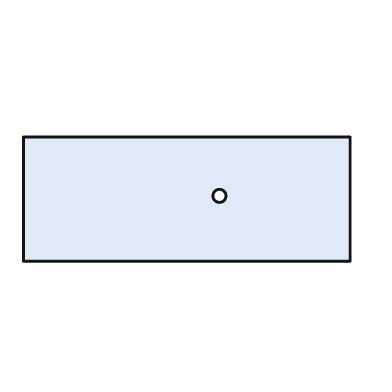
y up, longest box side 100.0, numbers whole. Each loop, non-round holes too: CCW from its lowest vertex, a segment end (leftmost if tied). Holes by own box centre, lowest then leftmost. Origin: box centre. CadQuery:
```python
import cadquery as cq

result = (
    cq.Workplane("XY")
    .moveTo(-50.0, -19.0)
    .lineTo(50.0, -19.0)
    .lineTo(50.0, 19.0)
    .lineTo(-50.0, 19.0)
    .close()
    .moveTo(10.0, 1.0)
    .circle(2.0)
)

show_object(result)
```